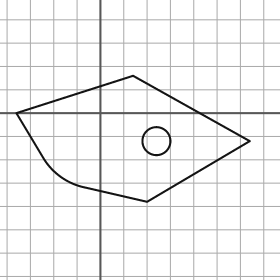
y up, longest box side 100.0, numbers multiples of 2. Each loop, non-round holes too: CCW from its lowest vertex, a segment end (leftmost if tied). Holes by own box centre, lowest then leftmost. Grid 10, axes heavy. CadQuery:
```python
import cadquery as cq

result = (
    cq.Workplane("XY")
    .moveTo(20.0, -38.0)
    .lineTo(64.0, -12.0)
    .lineTo(14.0, 16.0)
    .lineTo(-36.0, 0.0)
    .lineTo(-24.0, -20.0)
    .threePointArc((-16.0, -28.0), (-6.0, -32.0))
    .close()
    .moveTo(24.0, -12.0)
    .circle(6.0)
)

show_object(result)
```